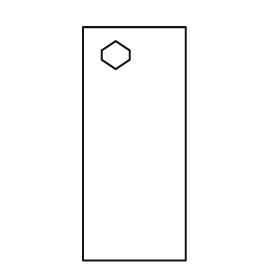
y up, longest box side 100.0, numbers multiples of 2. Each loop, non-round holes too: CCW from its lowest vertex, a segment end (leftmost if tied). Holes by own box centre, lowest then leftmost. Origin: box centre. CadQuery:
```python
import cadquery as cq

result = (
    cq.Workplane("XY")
    .moveTo(-22.0, -50.0)
    .lineTo(22.0, -50.0)
    .lineTo(22.0, 50.0)
    .lineTo(-22.0, 50.0)
    .close()
    .moveTo(-8.0, 32.0)
    .lineTo(-2.0, 36.0)
    .lineTo(-2.0, 40.0)
    .lineTo(-8.0, 44.0)
    .lineTo(-14.0, 40.0)
    .lineTo(-14.0, 36.0)
    .close()
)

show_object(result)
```